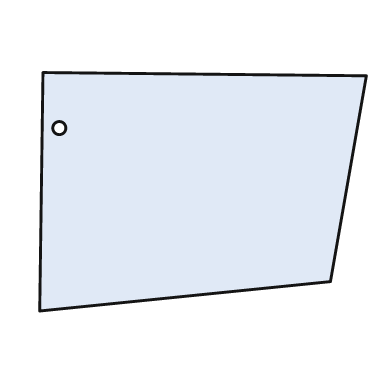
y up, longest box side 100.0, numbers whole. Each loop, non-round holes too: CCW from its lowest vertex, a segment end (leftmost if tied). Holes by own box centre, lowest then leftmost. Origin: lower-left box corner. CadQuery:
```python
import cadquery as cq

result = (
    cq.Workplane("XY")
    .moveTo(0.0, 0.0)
    .lineTo(89.0, 9.0)
    .lineTo(100.0, 72.0)
    .lineTo(1.0, 73.0)
    .close()
    .moveTo(6.0, 56.0)
    .circle(2.0)
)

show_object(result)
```